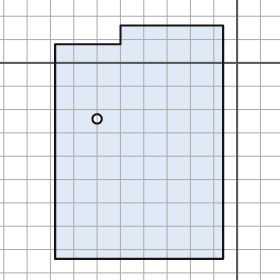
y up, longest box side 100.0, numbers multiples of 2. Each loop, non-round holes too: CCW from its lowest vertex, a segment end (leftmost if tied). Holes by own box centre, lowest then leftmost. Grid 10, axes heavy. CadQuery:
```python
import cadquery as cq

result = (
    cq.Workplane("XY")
    .moveTo(-78.0, -84.0)
    .lineTo(-6.0, -84.0)
    .lineTo(-6.0, 16.0)
    .lineTo(-50.0, 16.0)
    .lineTo(-50.0, 8.0)
    .lineTo(-78.0, 8.0)
    .close()
    .moveTo(-60.0, -24.0)
    .circle(2.0)
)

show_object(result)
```